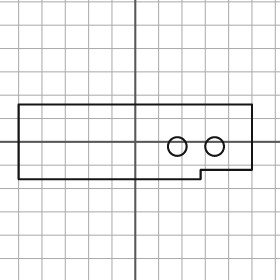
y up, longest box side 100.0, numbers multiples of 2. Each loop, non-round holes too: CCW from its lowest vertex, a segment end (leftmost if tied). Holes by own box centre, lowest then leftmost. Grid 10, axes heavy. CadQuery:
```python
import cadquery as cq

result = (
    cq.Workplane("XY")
    .moveTo(-50.0, -16.0)
    .lineTo(28.0, -16.0)
    .lineTo(28.0, -12.0)
    .lineTo(50.0, -12.0)
    .lineTo(50.0, 16.0)
    .lineTo(-50.0, 16.0)
    .close()
    .moveTo(18.0, -2.0)
    .circle(4.0)
    .moveTo(34.0, -2.0)
    .circle(4.0)
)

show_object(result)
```